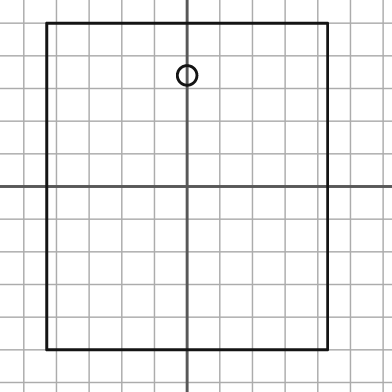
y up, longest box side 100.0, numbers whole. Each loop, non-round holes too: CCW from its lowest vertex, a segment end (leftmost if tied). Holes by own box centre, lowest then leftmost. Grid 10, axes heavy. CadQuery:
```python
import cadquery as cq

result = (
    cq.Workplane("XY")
    .moveTo(-43.0, -50.0)
    .lineTo(43.0, -50.0)
    .lineTo(43.0, 50.0)
    .lineTo(-43.0, 50.0)
    .close()
    .moveTo(0.0, 34.0)
    .circle(3.0)
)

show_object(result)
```